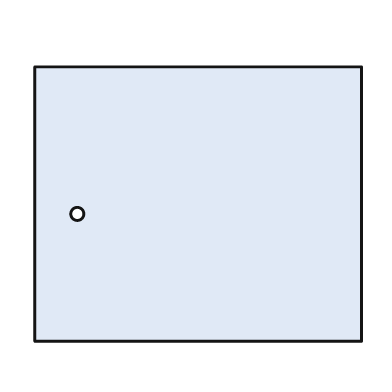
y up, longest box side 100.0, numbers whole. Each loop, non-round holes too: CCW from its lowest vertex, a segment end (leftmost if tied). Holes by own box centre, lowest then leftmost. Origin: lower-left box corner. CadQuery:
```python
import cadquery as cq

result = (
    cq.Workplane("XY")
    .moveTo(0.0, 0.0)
    .lineTo(100.0, 0.0)
    .lineTo(100.0, 84.0)
    .lineTo(0.0, 84.0)
    .close()
    .moveTo(13.0, 39.0)
    .circle(2.0)
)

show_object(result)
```